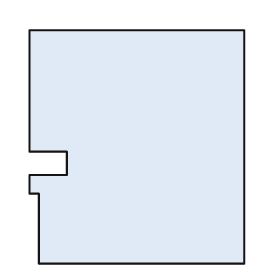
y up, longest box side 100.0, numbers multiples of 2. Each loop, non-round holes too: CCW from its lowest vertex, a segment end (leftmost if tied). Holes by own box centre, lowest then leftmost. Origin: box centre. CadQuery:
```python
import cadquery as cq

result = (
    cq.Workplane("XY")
    .moveTo(-42.0, -50.0)
    .lineTo(46.0, -50.0)
    .lineTo(46.0, 50.0)
    .lineTo(-46.0, 50.0)
    .lineTo(-46.0, -2.0)
    .lineTo(-30.0, -2.0)
    .lineTo(-30.0, -12.0)
    .lineTo(-46.0, -12.0)
    .lineTo(-46.0, -20.0)
    .lineTo(-42.0, -20.0)
    .close()
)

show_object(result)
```